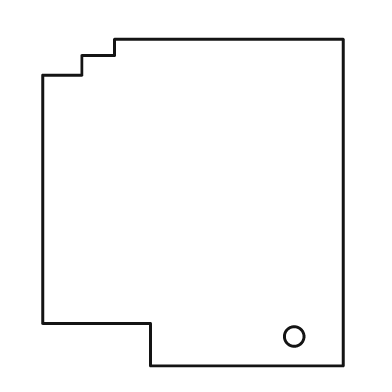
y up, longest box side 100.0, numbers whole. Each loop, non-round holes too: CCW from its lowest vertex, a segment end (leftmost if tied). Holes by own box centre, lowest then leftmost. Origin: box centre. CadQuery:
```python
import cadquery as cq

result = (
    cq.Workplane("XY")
    .moveTo(-13.0, -50.0)
    .lineTo(46.0, -50.0)
    .lineTo(46.0, 50.0)
    .lineTo(-24.0, 50.0)
    .lineTo(-24.0, 45.0)
    .lineTo(-34.0, 45.0)
    .lineTo(-34.0, 39.0)
    .lineTo(-46.0, 39.0)
    .lineTo(-46.0, -37.0)
    .lineTo(-13.0, -37.0)
    .close()
    .moveTo(31.0, -41.0)
    .circle(3.0)
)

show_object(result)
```